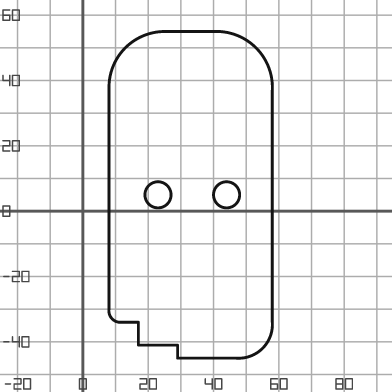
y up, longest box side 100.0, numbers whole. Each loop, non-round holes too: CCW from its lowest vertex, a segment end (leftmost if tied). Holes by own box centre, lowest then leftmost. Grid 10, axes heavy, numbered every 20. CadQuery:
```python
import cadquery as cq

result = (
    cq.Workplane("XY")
    .moveTo(29.0, -45.0)
    .lineTo(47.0, -45.0)
    .threePointArc((55.0, -42.0), (58.0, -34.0))
    .lineTo(58.0, 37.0)
    .threePointArc((53.0, 50.0), (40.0, 55.0))
    .lineTo(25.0, 55.0)
    .threePointArc((13.0, 50.0), (8.0, 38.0))
    .lineTo(8.0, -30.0)
    .threePointArc((9.0, -33.0), (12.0, -34.0))
    .lineTo(17.0, -34.0)
    .lineTo(17.0, -41.0)
    .lineTo(29.0, -41.0)
    .close()
    .moveTo(23.0, 5.0)
    .circle(4.0)
    .moveTo(44.0, 5.0)
    .circle(4.0)
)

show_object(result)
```